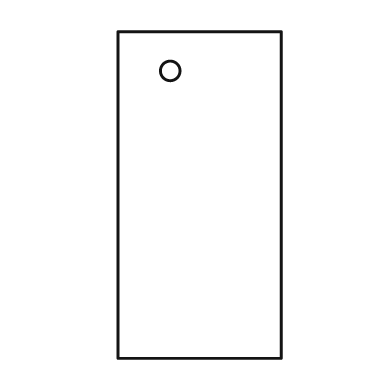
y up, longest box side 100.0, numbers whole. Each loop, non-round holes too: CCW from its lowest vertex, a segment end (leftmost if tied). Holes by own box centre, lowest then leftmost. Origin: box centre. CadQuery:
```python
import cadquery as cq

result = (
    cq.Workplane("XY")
    .moveTo(-25.0, -50.0)
    .lineTo(25.0, -50.0)
    .lineTo(25.0, 50.0)
    .lineTo(-25.0, 50.0)
    .close()
    .moveTo(-9.0, 38.0)
    .circle(3.0)
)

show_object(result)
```